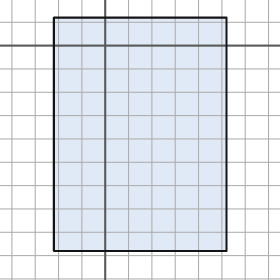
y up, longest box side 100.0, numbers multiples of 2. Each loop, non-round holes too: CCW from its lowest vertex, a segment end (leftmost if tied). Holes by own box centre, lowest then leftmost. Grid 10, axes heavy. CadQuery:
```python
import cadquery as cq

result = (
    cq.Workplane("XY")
    .moveTo(-22.0, -88.0)
    .lineTo(52.0, -88.0)
    .lineTo(52.0, 12.0)
    .lineTo(-22.0, 12.0)
    .close()
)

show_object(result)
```